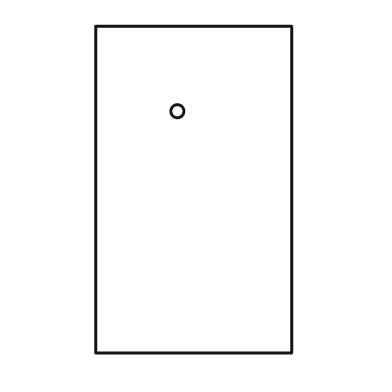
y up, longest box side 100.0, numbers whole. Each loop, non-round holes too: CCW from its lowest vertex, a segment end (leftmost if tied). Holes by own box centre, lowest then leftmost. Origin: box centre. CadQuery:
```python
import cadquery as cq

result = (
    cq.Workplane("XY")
    .moveTo(-30.0, -50.0)
    .lineTo(30.0, -50.0)
    .lineTo(30.0, 50.0)
    .lineTo(-30.0, 50.0)
    .close()
    .moveTo(-5.0, 24.0)
    .circle(2.0)
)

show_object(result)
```